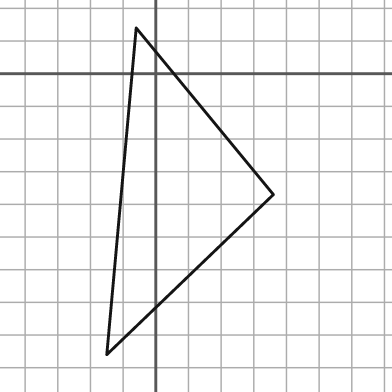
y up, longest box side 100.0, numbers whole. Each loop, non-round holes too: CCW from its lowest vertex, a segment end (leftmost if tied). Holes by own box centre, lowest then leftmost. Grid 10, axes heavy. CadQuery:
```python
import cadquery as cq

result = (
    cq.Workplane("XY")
    .moveTo(-15.0, -86.0)
    .lineTo(36.0, -37.0)
    .lineTo(-6.0, 14.0)
    .close()
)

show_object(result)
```